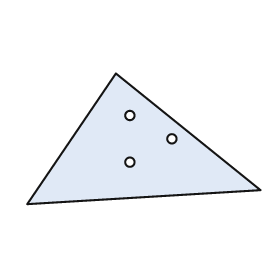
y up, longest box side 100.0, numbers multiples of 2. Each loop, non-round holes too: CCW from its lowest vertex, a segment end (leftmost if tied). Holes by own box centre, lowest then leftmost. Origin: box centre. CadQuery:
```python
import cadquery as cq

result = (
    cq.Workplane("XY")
    .moveTo(-50.0, -28.0)
    .lineTo(50.0, -22.0)
    .lineTo(-12.0, 28.0)
    .close()
    .moveTo(-6.0, -10.0)
    .circle(2.0)
    .moveTo(12.0, 0.0)
    .circle(2.0)
    .moveTo(-6.0, 10.0)
    .circle(2.0)
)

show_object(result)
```